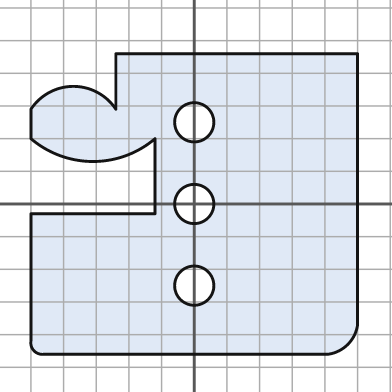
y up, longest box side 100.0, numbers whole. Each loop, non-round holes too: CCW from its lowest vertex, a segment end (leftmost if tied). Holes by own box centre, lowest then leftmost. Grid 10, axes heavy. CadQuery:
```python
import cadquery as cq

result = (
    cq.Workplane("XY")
    .moveTo(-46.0, -46.0)
    .lineTo(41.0, -46.0)
    .threePointArc((47.0, -43.0), (50.0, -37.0))
    .lineTo(50.0, 46.0)
    .lineTo(-24.0, 46.0)
    .lineTo(-24.0, 29.0)
    .threePointArc((-37.0, 36.0), (-50.0, 29.0))
    .lineTo(-50.0, 20.0)
    .threePointArc((-31.0, 13.0), (-12.0, 20.0))
    .lineTo(-12.0, -3.0)
    .lineTo(-50.0, -3.0)
    .lineTo(-50.0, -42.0)
    .threePointArc((-49.0, -45.0), (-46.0, -46.0))
    .close()
    .moveTo(0.0, -25.0)
    .circle(6.0)
    .moveTo(0.0, 0.0)
    .circle(6.0)
    .moveTo(0.0, 25.0)
    .circle(6.0)
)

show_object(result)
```